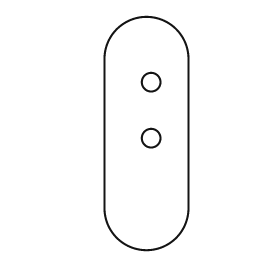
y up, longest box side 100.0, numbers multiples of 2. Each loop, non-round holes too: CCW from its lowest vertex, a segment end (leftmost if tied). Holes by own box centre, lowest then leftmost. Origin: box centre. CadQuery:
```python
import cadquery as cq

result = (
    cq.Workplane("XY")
    .moveTo(-18.0, -32.0)
    .threePointArc((0.0, -50.0), (18.0, -32.0))
    .lineTo(18.0, 32.0)
    .threePointArc((0.0, 50.0), (-18.0, 32.0))
    .close()
    .moveTo(2.0, -2.0)
    .circle(4.0)
    .moveTo(2.0, 22.0)
    .circle(4.0)
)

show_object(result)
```